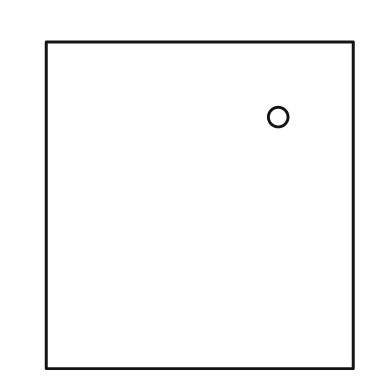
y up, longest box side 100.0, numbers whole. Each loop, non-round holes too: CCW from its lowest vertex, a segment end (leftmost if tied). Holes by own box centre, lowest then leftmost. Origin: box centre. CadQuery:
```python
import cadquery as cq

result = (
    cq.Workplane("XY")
    .moveTo(-47.0, -50.0)
    .lineTo(47.0, -50.0)
    .lineTo(47.0, 50.0)
    .lineTo(-47.0, 50.0)
    .close()
    .moveTo(24.0, 27.0)
    .circle(3.0)
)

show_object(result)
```